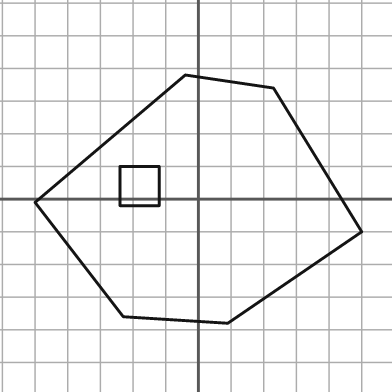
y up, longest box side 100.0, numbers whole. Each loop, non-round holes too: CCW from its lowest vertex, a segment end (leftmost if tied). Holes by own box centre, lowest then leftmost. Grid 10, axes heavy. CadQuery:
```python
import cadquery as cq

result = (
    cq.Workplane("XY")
    .moveTo(9.0, -38.0)
    .lineTo(50.0, -10.0)
    .lineTo(23.0, 34.0)
    .lineTo(-4.0, 38.0)
    .lineTo(-50.0, -1.0)
    .lineTo(-23.0, -36.0)
    .close()
    .moveTo(-24.0, -2.0)
    .lineTo(-12.0, -2.0)
    .lineTo(-12.0, 10.0)
    .lineTo(-24.0, 10.0)
    .close()
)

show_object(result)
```